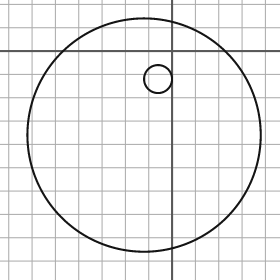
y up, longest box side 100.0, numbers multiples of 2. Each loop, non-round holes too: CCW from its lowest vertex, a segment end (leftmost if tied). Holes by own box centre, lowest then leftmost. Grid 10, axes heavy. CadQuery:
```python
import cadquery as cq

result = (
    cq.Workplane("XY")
    .moveTo(-12.0, -36.0)
    .circle(50.0)
    .moveTo(-6.0, -12.0)
    .circle(6.0)
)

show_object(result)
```